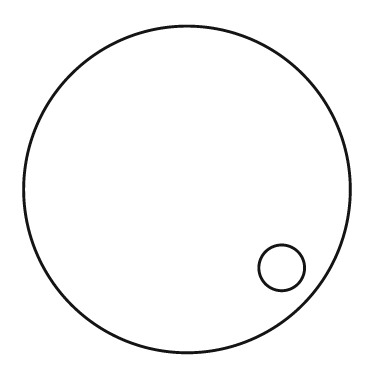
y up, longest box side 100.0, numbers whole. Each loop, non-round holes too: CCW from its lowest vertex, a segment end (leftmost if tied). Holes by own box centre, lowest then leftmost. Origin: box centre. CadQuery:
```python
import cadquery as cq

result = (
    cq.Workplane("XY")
    .moveTo(0.0, 0.0)
    .circle(50.0)
    .moveTo(29.0, -24.0)
    .circle(7.0)
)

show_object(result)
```